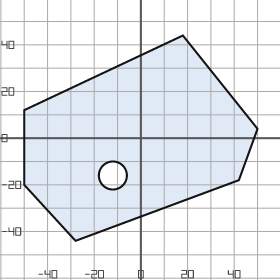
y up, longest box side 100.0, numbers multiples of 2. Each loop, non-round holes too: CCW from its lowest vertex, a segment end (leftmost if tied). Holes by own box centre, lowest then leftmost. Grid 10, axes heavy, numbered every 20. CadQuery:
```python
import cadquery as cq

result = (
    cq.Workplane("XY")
    .moveTo(-28.0, -44.0)
    .lineTo(42.0, -18.0)
    .lineTo(50.0, 4.0)
    .lineTo(18.0, 44.0)
    .lineTo(-50.0, 12.0)
    .lineTo(-50.0, -20.0)
    .close()
    .moveTo(-12.0, -16.0)
    .circle(6.0)
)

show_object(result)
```